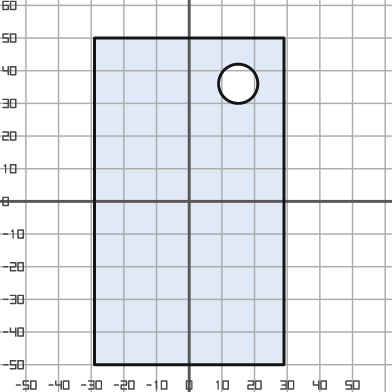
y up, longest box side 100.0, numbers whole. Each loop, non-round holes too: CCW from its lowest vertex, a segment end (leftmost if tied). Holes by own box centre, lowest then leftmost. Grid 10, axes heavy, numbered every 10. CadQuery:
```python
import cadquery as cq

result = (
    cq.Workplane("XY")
    .moveTo(-29.0, -50.0)
    .lineTo(29.0, -50.0)
    .lineTo(29.0, 50.0)
    .lineTo(-29.0, 50.0)
    .close()
    .moveTo(15.0, 36.0)
    .circle(6.0)
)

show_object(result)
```